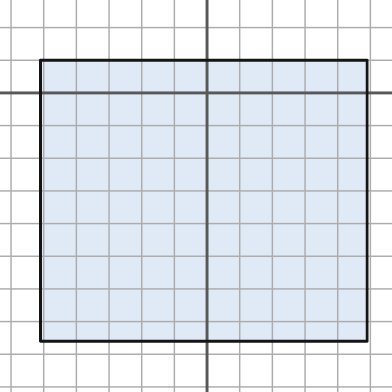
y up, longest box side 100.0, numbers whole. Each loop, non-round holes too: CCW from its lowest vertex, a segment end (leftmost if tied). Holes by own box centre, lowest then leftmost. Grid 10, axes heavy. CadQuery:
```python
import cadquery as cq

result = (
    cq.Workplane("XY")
    .moveTo(-51.0, -76.0)
    .lineTo(49.0, -76.0)
    .lineTo(49.0, 10.0)
    .lineTo(-51.0, 10.0)
    .close()
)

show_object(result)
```